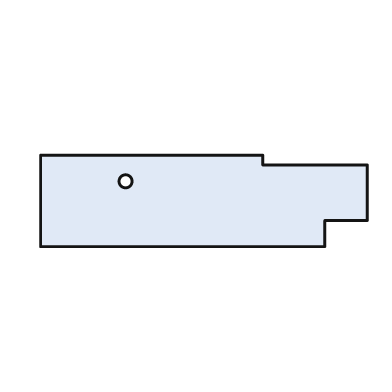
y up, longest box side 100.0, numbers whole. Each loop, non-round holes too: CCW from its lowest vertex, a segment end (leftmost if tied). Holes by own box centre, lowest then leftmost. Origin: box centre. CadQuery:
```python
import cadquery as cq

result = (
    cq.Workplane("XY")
    .moveTo(-50.0, -14.0)
    .lineTo(37.0, -14.0)
    .lineTo(37.0, -6.0)
    .lineTo(50.0, -6.0)
    .lineTo(50.0, 11.0)
    .lineTo(18.0, 11.0)
    .lineTo(18.0, 14.0)
    .lineTo(-50.0, 14.0)
    .close()
    .moveTo(-24.0, 6.0)
    .circle(2.0)
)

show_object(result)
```